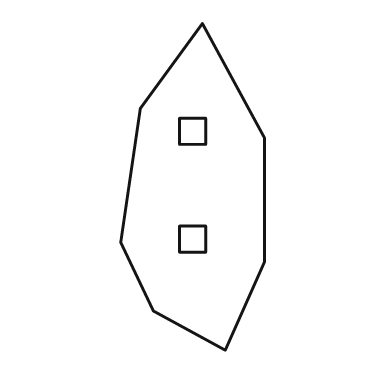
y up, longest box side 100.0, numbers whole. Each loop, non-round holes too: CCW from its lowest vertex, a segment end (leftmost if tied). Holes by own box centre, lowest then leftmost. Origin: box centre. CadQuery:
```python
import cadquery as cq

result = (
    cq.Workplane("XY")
    .moveTo(10.0, -50.0)
    .lineTo(22.0, -23.0)
    .lineTo(22.0, 15.0)
    .lineTo(3.0, 50.0)
    .lineTo(-16.0, 24.0)
    .lineTo(-22.0, -17.0)
    .lineTo(-12.0, -38.0)
    .close()
    .moveTo(-4.0, -20.0)
    .lineTo(4.0, -20.0)
    .lineTo(4.0, -12.0)
    .lineTo(-4.0, -12.0)
    .close()
    .moveTo(-4.0, 13.0)
    .lineTo(4.0, 13.0)
    .lineTo(4.0, 21.0)
    .lineTo(-4.0, 21.0)
    .close()
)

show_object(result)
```